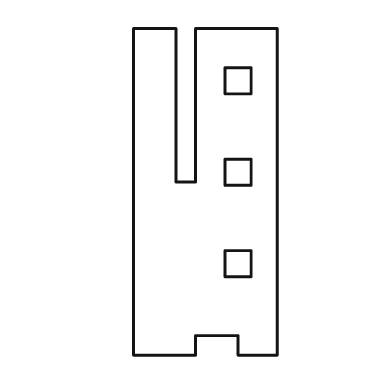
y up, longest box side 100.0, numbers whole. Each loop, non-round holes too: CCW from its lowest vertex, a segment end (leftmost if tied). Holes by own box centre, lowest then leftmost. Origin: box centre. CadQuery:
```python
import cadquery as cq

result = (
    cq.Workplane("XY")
    .moveTo(-22.0, -50.0)
    .lineTo(-3.0, -50.0)
    .lineTo(-3.0, -44.0)
    .lineTo(10.0, -44.0)
    .lineTo(10.0, -50.0)
    .lineTo(22.0, -50.0)
    .lineTo(22.0, 50.0)
    .lineTo(-3.0, 50.0)
    .lineTo(-3.0, 3.0)
    .lineTo(-9.0, 3.0)
    .lineTo(-9.0, 50.0)
    .lineTo(-22.0, 50.0)
    .close()
    .moveTo(6.0, -26.0)
    .lineTo(14.0, -26.0)
    .lineTo(14.0, -18.0)
    .lineTo(6.0, -18.0)
    .close()
    .moveTo(6.0, 2.0)
    .lineTo(14.0, 2.0)
    .lineTo(14.0, 10.0)
    .lineTo(6.0, 10.0)
    .close()
    .moveTo(6.0, 30.0)
    .lineTo(14.0, 30.0)
    .lineTo(14.0, 38.0)
    .lineTo(6.0, 38.0)
    .close()
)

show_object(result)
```